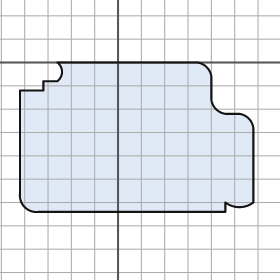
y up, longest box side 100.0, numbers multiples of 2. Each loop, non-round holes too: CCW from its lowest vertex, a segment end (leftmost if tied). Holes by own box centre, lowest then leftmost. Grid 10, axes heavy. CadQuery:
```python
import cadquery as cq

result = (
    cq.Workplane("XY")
    .moveTo(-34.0, -64.0)
    .lineTo(46.0, -64.0)
    .lineTo(46.0, -60.0)
    .threePointArc((52.0, -62.0), (58.0, -60.0))
    .lineTo(58.0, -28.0)
    .threePointArc((56.0, -24.0), (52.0, -22.0))
    .lineTo(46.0, -22.0)
    .threePointArc((42.0, -20.0), (40.0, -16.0))
    .lineTo(40.0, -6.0)
    .threePointArc((38.0, -2.0), (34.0, 0.0))
    .lineTo(-26.0, 0.0)
    .threePointArc((-24.0, -4.0), (-26.0, -8.0))
    .lineTo(-32.0, -8.0)
    .lineTo(-32.0, -12.0)
    .lineTo(-42.0, -12.0)
    .lineTo(-42.0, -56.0)
    .threePointArc((-40.0, -62.0), (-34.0, -64.0))
    .close()
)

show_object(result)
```